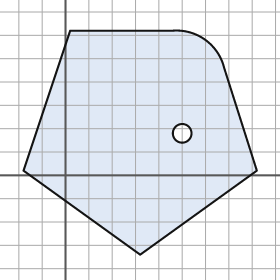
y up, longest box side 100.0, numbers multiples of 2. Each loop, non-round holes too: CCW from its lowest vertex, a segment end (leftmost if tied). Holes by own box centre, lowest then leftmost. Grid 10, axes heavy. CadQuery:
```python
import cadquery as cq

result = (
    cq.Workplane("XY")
    .moveTo(32.0, -34.0)
    .lineTo(82.0, 2.0)
    .lineTo(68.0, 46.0)
    .threePointArc((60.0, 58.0), (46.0, 62.0))
    .lineTo(2.0, 62.0)
    .lineTo(-18.0, 2.0)
    .close()
    .moveTo(50.0, 18.0)
    .circle(4.0)
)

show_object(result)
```